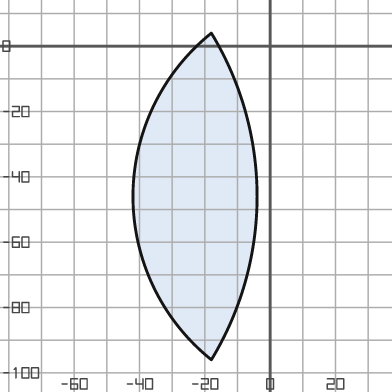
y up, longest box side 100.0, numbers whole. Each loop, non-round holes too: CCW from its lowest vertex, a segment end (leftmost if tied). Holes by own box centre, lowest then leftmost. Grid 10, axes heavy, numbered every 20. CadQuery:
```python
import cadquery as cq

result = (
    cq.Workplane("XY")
    .moveTo(-18.0, -96.0)
    .threePointArc((-4.0, -46.0), (-18.0, 4.0))
    .threePointArc((-42.0, -46.0), (-18.0, -96.0))
    .close()
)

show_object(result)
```